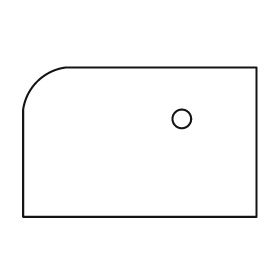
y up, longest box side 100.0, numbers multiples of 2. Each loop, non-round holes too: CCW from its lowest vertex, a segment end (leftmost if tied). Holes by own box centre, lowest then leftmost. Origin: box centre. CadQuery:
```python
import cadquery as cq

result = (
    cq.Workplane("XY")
    .moveTo(-50.0, -32.0)
    .lineTo(50.0, -32.0)
    .lineTo(50.0, 32.0)
    .lineTo(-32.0, 32.0)
    .threePointArc((-44.0, 26.0), (-50.0, 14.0))
    .close()
    .moveTo(18.0, 10.0)
    .circle(4.0)
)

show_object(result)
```